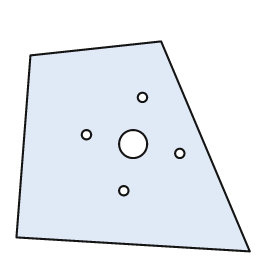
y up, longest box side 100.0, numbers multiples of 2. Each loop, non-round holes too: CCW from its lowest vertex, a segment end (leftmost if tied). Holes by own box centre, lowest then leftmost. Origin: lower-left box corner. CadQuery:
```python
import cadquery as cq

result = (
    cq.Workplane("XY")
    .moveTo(100.0, 0.0)
    .lineTo(62.0, 90.0)
    .lineTo(6.0, 84.0)
    .lineTo(0.0, 6.0)
    .close()
    .moveTo(46.0, 26.0)
    .circle(2.0)
    .moveTo(70.0, 42.0)
    .circle(2.0)
    .moveTo(50.0, 46.0)
    .circle(6.0)
    .moveTo(30.0, 50.0)
    .circle(2.0)
    .moveTo(54.0, 66.0)
    .circle(2.0)
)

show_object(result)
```